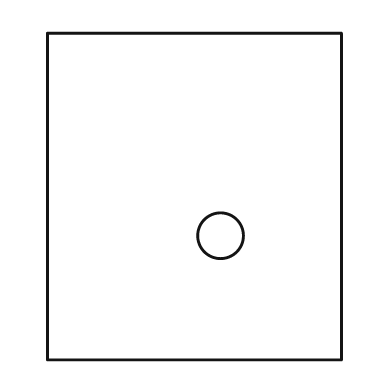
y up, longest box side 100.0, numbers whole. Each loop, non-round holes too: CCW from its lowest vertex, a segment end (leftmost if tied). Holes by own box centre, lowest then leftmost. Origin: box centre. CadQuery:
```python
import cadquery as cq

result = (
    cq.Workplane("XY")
    .moveTo(-45.0, -50.0)
    .lineTo(45.0, -50.0)
    .lineTo(45.0, 50.0)
    .lineTo(-45.0, 50.0)
    .close()
    .moveTo(8.0, -12.0)
    .circle(7.0)
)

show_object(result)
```